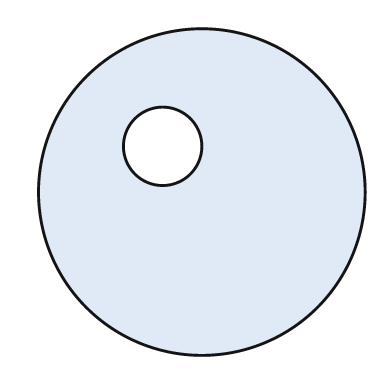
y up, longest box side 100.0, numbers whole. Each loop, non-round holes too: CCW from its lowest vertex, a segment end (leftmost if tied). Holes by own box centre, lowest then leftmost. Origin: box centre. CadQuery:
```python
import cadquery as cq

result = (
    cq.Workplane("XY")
    .moveTo(0.0, 0.0)
    .circle(50.0)
    .moveTo(-12.0, 14.0)
    .circle(12.0)
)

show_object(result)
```